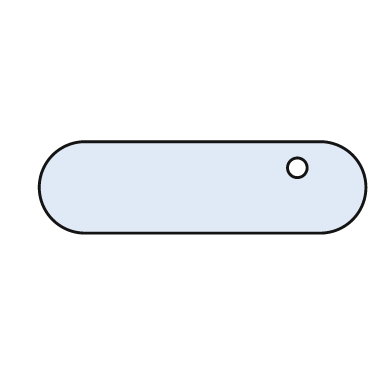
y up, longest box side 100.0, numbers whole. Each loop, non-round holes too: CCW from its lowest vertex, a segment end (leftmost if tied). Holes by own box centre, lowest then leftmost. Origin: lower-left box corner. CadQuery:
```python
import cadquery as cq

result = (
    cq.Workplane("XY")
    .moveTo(14.0, 0.0)
    .lineTo(86.0, 0.0)
    .threePointArc((100.0, 14.0), (86.0, 28.0))
    .lineTo(14.0, 28.0)
    .threePointArc((0.0, 14.0), (14.0, 0.0))
    .close()
    .moveTo(79.0, 20.0)
    .circle(3.0)
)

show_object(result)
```